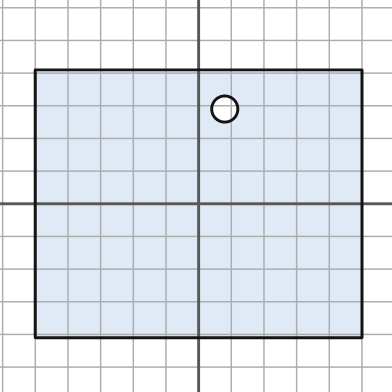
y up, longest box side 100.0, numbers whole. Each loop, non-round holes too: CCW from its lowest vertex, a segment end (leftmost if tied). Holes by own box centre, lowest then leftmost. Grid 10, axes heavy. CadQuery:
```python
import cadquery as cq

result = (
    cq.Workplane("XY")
    .moveTo(-50.0, -41.0)
    .lineTo(50.0, -41.0)
    .lineTo(50.0, 41.0)
    .lineTo(-50.0, 41.0)
    .close()
    .moveTo(8.0, 29.0)
    .circle(4.0)
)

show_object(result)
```